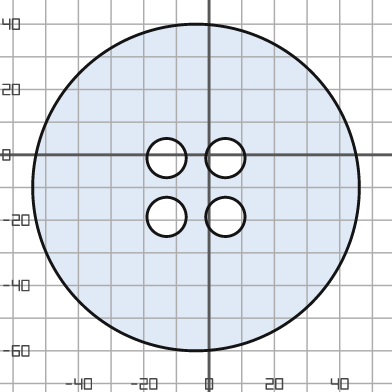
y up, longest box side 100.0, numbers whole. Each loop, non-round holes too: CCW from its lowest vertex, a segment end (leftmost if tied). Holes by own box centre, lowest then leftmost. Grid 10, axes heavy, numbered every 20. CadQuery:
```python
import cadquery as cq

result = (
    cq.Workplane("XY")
    .moveTo(-4.0, -10.0)
    .circle(50.0)
    .moveTo(-13.0, -19.0)
    .circle(6.0)
    .moveTo(5.0, -19.0)
    .circle(6.0)
    .moveTo(-13.0, -1.0)
    .circle(6.0)
    .moveTo(5.0, -1.0)
    .circle(6.0)
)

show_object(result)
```